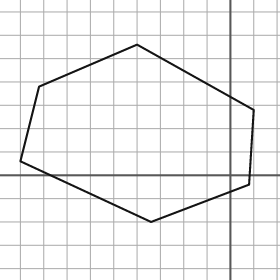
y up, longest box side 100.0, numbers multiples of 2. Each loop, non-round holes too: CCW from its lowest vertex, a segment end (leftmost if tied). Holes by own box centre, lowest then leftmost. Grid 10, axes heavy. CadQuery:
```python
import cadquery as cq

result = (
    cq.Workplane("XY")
    .moveTo(-34.0, -20.0)
    .lineTo(8.0, -4.0)
    .lineTo(10.0, 28.0)
    .lineTo(-40.0, 56.0)
    .lineTo(-82.0, 38.0)
    .lineTo(-90.0, 6.0)
    .close()
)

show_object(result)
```